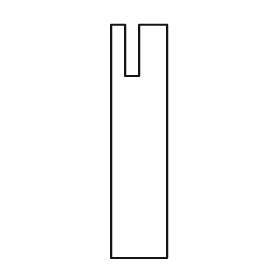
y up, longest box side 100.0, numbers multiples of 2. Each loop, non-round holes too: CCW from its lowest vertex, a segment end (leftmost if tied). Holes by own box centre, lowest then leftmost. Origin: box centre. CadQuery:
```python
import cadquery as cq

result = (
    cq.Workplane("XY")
    .moveTo(-12.0, -50.0)
    .lineTo(12.0, -50.0)
    .lineTo(12.0, 50.0)
    .lineTo(0.0, 50.0)
    .lineTo(0.0, 28.0)
    .lineTo(-6.0, 28.0)
    .lineTo(-6.0, 50.0)
    .lineTo(-12.0, 50.0)
    .close()
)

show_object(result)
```